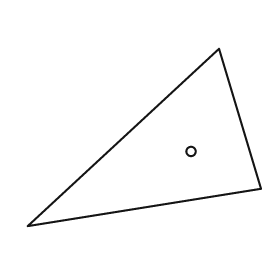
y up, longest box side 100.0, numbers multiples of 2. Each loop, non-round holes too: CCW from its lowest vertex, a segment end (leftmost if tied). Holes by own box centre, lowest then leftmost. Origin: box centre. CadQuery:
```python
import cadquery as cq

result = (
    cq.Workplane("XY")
    .moveTo(-50.0, -38.0)
    .lineTo(50.0, -22.0)
    .lineTo(32.0, 38.0)
    .close()
    .moveTo(20.0, -6.0)
    .circle(2.0)
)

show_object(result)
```